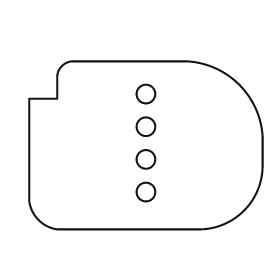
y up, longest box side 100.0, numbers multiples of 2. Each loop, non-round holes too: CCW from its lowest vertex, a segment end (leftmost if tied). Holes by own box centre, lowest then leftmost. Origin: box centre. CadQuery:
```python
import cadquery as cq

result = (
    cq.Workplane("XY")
    .moveTo(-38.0, -36.0)
    .lineTo(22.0, -36.0)
    .threePointArc((42.0, -28.0), (50.0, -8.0))
    .lineTo(50.0, 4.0)
    .threePointArc((40.0, 26.0), (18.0, 36.0))
    .lineTo(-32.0, 36.0)
    .threePointArc((-36.0, 34.0), (-38.0, 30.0))
    .lineTo(-38.0, 20.0)
    .lineTo(-50.0, 20.0)
    .lineTo(-50.0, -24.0)
    .threePointArc((-46.0, -32.0), (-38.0, -36.0))
    .close()
    .moveTo(0.0, -20.0)
    .circle(4.0)
    .moveTo(0.0, -6.0)
    .circle(4.0)
    .moveTo(0.0, 8.0)
    .circle(4.0)
    .moveTo(0.0, 22.0)
    .circle(4.0)
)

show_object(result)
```